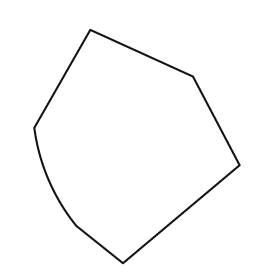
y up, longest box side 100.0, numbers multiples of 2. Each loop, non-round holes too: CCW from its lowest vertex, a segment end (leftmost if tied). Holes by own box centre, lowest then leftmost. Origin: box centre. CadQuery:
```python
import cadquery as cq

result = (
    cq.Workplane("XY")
    .moveTo(-6.0, -50.0)
    .lineTo(44.0, -8.0)
    .lineTo(24.0, 30.0)
    .lineTo(-20.0, 50.0)
    .lineTo(-44.0, 8.0)
    .threePointArc((-38.0, -14.0), (-26.0, -34.0))
    .close()
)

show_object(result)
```